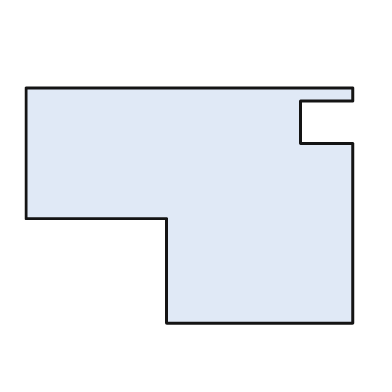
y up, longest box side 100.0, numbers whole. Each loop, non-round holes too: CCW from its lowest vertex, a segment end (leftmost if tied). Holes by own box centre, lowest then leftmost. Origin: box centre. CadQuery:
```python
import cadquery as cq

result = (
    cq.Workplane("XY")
    .moveTo(-7.0, -36.0)
    .lineTo(50.0, -36.0)
    .lineTo(50.0, 19.0)
    .lineTo(34.0, 19.0)
    .lineTo(34.0, 32.0)
    .lineTo(50.0, 32.0)
    .lineTo(50.0, 36.0)
    .lineTo(-50.0, 36.0)
    .lineTo(-50.0, -4.0)
    .lineTo(-7.0, -4.0)
    .close()
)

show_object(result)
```